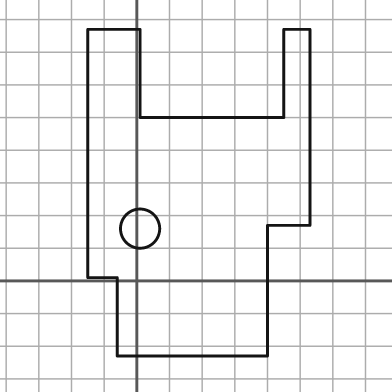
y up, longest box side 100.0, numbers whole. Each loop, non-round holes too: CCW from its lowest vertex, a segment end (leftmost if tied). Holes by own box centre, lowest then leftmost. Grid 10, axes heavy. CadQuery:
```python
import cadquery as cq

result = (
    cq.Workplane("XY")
    .moveTo(-6.0, -23.0)
    .lineTo(40.0, -23.0)
    .lineTo(40.0, 17.0)
    .lineTo(53.0, 17.0)
    .lineTo(53.0, 77.0)
    .lineTo(45.0, 77.0)
    .lineTo(45.0, 50.0)
    .lineTo(1.0, 50.0)
    .lineTo(1.0, 77.0)
    .lineTo(-15.0, 77.0)
    .lineTo(-15.0, 1.0)
    .lineTo(-6.0, 1.0)
    .close()
    .moveTo(1.0, 16.0)
    .circle(6.0)
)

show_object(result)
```